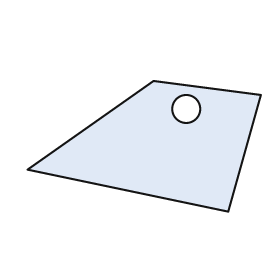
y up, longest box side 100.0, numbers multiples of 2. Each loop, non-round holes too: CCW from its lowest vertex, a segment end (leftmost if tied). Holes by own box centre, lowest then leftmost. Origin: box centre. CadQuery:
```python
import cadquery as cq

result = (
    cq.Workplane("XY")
    .moveTo(36.0, -28.0)
    .lineTo(50.0, 22.0)
    .lineTo(4.0, 28.0)
    .lineTo(-50.0, -10.0)
    .close()
    .moveTo(18.0, 16.0)
    .circle(6.0)
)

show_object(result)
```